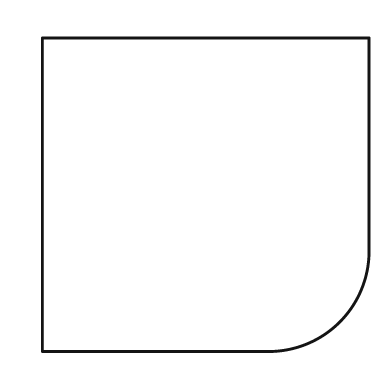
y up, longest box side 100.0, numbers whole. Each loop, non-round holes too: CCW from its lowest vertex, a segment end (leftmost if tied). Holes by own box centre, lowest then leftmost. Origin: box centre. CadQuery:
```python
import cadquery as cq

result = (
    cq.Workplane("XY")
    .moveTo(-50.0, -48.0)
    .lineTo(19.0, -48.0)
    .threePointArc((41.0, -39.0), (50.0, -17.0))
    .lineTo(50.0, 48.0)
    .lineTo(-50.0, 48.0)
    .close()
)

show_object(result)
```